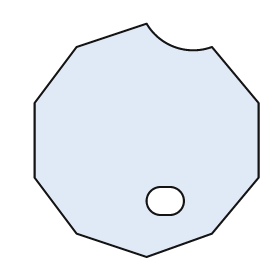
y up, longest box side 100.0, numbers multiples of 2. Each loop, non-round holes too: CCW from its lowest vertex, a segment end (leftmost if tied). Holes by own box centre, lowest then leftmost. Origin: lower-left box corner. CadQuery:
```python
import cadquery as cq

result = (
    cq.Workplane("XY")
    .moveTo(48.0, 0.0)
    .lineTo(76.0, 10.0)
    .lineTo(96.0, 34.0)
    .lineTo(96.0, 66.0)
    .lineTo(76.0, 90.0)
    .threePointArc((60.0, 90.0), (48.0, 100.0))
    .lineTo(18.0, 90.0)
    .lineTo(0.0, 66.0)
    .lineTo(0.0, 34.0)
    .lineTo(18.0, 10.0)
    .close()
    .moveTo(54.0, 18.0)
    .lineTo(58.0, 18.0)
    .threePointArc((64.0, 24.0), (58.0, 30.0))
    .lineTo(54.0, 30.0)
    .threePointArc((48.0, 24.0), (54.0, 18.0))
    .close()
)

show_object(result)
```